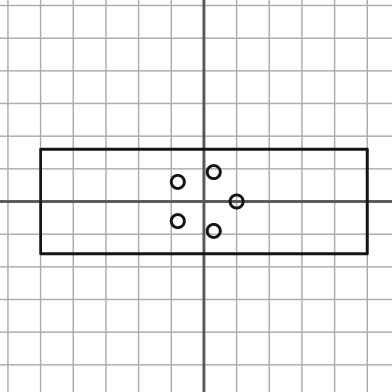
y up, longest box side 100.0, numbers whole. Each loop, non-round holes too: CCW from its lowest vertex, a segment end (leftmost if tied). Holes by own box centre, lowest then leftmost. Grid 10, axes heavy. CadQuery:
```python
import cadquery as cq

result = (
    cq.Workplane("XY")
    .moveTo(-50.0, -16.0)
    .lineTo(50.0, -16.0)
    .lineTo(50.0, 16.0)
    .lineTo(-50.0, 16.0)
    .close()
    .moveTo(3.0, -9.0)
    .circle(2.0)
    .moveTo(-8.0, -6.0)
    .circle(2.0)
    .moveTo(10.0, 0.0)
    .circle(2.0)
    .moveTo(-8.0, 6.0)
    .circle(2.0)
    .moveTo(3.0, 9.0)
    .circle(2.0)
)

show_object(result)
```